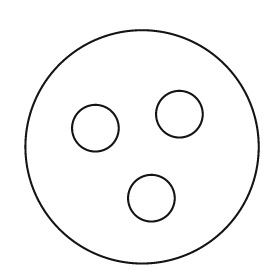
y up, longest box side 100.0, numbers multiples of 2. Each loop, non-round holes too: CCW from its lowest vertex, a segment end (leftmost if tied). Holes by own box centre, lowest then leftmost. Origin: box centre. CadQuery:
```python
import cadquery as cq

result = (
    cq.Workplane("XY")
    .moveTo(0.0, 0.0)
    .circle(50.0)
    .moveTo(4.0, -22.0)
    .circle(10.0)
    .moveTo(-20.0, 8.0)
    .circle(10.0)
    .moveTo(16.0, 14.0)
    .circle(10.0)
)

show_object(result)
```